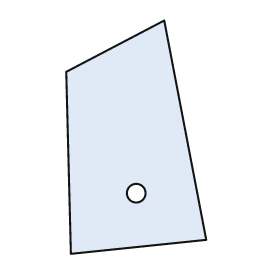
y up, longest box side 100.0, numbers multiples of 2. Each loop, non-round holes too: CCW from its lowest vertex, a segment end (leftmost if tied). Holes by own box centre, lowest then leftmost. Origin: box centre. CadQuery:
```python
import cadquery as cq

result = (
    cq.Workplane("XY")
    .moveTo(-28.0, -50.0)
    .lineTo(30.0, -44.0)
    .lineTo(12.0, 50.0)
    .lineTo(-30.0, 28.0)
    .close()
    .moveTo(0.0, -24.0)
    .circle(4.0)
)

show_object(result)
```